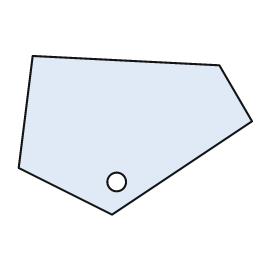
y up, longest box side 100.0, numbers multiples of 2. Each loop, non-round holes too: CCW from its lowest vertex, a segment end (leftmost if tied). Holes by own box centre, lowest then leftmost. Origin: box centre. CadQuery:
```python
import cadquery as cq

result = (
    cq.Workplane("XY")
    .moveTo(-10.0, -34.0)
    .lineTo(50.0, 6.0)
    .lineTo(36.0, 30.0)
    .lineTo(-44.0, 34.0)
    .lineTo(-50.0, -14.0)
    .close()
    .moveTo(-8.0, -20.0)
    .circle(4.0)
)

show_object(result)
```